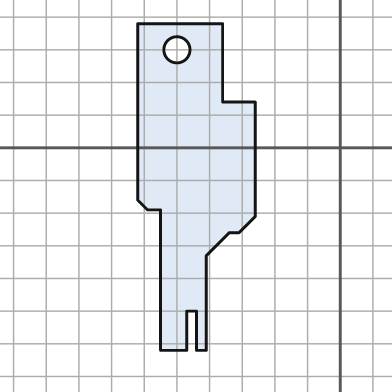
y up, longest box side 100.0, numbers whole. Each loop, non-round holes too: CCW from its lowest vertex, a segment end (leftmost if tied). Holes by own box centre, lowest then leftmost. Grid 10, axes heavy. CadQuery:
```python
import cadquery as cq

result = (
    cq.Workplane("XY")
    .moveTo(-55.0, -62.0)
    .lineTo(-47.0, -62.0)
    .lineTo(-47.0, -50.0)
    .lineTo(-44.0, -50.0)
    .lineTo(-44.0, -62.0)
    .lineTo(-41.0, -62.0)
    .lineTo(-41.0, -33.0)
    .lineTo(-34.0, -26.0)
    .lineTo(-31.0, -26.0)
    .lineTo(-26.0, -21.0)
    .lineTo(-26.0, 14.0)
    .lineTo(-36.0, 14.0)
    .lineTo(-36.0, 38.0)
    .lineTo(-62.0, 38.0)
    .lineTo(-62.0, -16.0)
    .lineTo(-59.0, -19.0)
    .lineTo(-55.0, -19.0)
    .close()
    .moveTo(-50.0, 30.0)
    .circle(4.0)
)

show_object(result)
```